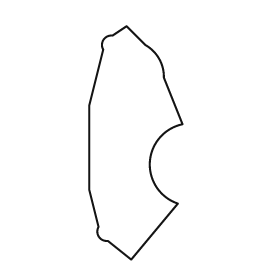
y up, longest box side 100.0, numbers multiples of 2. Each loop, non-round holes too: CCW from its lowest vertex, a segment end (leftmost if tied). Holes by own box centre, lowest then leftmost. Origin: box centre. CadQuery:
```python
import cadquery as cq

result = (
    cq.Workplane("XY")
    .moveTo(-2.0, -50.0)
    .lineTo(18.0, -26.0)
    .threePointArc((6.0, -8.0), (20.0, 8.0))
    .lineTo(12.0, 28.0)
    .threePointArc((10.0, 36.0), (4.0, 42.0))
    .lineTo(-4.0, 50.0)
    .lineTo(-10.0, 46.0)
    .threePointArc((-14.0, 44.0), (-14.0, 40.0))
    .lineTo(-20.0, 16.0)
    .lineTo(-20.0, -20.0)
    .lineTo(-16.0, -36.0)
    .threePointArc((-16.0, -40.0), (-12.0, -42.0))
    .close()
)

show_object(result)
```